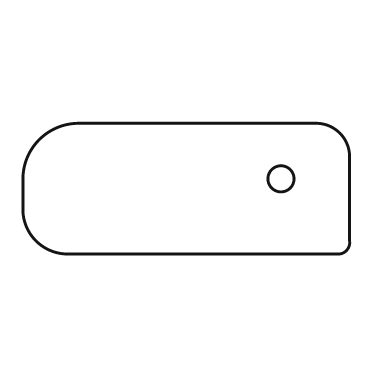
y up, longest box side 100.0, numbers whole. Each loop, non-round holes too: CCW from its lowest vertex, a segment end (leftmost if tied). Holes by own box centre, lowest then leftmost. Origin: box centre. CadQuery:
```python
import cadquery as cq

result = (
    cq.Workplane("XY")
    .moveTo(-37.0, -20.0)
    .lineTo(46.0, -20.0)
    .threePointArc((49.0, -19.0), (50.0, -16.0))
    .lineTo(50.0, 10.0)
    .threePointArc((47.0, 17.0), (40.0, 20.0))
    .lineTo(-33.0, 20.0)
    .threePointArc((-45.0, 15.0), (-50.0, 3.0))
    .lineTo(-50.0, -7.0)
    .threePointArc((-46.0, -16.0), (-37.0, -20.0))
    .close()
    .moveTo(29.0, 3.0)
    .circle(4.0)
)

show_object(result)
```